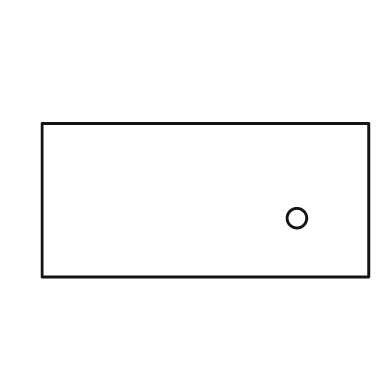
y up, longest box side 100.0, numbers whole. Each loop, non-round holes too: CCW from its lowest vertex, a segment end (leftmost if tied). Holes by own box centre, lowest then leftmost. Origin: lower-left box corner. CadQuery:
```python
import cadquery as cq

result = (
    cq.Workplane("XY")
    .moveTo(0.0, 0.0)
    .lineTo(100.0, 0.0)
    .lineTo(100.0, 47.0)
    .lineTo(0.0, 47.0)
    .close()
    .moveTo(78.0, 18.0)
    .circle(3.0)
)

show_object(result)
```